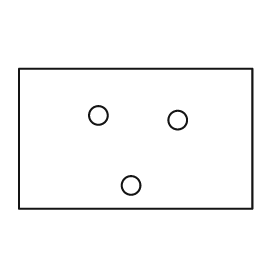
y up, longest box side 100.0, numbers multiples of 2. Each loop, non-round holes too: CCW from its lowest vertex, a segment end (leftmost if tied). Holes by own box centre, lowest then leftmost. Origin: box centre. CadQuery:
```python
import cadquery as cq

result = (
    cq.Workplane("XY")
    .moveTo(-50.0, -30.0)
    .lineTo(50.0, -30.0)
    .lineTo(50.0, 30.0)
    .lineTo(-50.0, 30.0)
    .close()
    .moveTo(-2.0, -20.0)
    .circle(4.0)
    .moveTo(18.0, 8.0)
    .circle(4.0)
    .moveTo(-16.0, 10.0)
    .circle(4.0)
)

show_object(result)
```